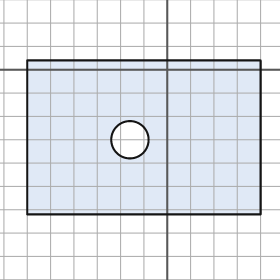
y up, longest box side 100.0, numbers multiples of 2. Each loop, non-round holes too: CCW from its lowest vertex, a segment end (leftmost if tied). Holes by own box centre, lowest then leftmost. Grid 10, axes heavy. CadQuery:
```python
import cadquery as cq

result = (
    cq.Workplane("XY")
    .moveTo(-60.0, -62.0)
    .lineTo(40.0, -62.0)
    .lineTo(40.0, 4.0)
    .lineTo(-60.0, 4.0)
    .close()
    .moveTo(-16.0, -30.0)
    .circle(8.0)
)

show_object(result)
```